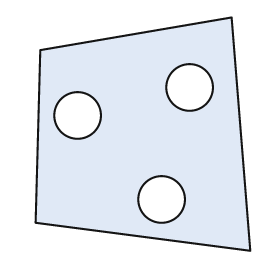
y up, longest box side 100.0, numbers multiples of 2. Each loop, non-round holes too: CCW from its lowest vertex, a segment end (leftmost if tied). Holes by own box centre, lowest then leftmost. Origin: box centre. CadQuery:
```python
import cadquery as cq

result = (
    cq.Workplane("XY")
    .moveTo(46.0, -50.0)
    .lineTo(38.0, 50.0)
    .lineTo(-44.0, 36.0)
    .lineTo(-46.0, -38.0)
    .close()
    .moveTo(8.0, -28.0)
    .circle(10.0)
    .moveTo(-28.0, 8.0)
    .circle(10.0)
    .moveTo(20.0, 20.0)
    .circle(10.0)
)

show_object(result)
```